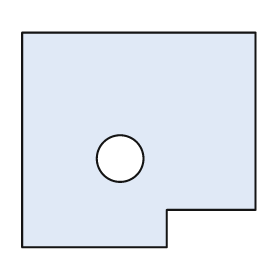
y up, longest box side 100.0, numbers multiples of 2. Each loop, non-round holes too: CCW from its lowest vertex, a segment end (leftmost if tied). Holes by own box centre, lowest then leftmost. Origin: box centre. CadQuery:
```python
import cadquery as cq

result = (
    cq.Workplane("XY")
    .moveTo(-50.0, -46.0)
    .lineTo(12.0, -46.0)
    .lineTo(12.0, -30.0)
    .lineTo(50.0, -30.0)
    .lineTo(50.0, 46.0)
    .lineTo(-50.0, 46.0)
    .close()
    .moveTo(-8.0, -8.0)
    .circle(10.0)
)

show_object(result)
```